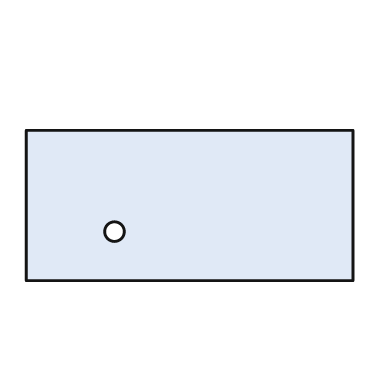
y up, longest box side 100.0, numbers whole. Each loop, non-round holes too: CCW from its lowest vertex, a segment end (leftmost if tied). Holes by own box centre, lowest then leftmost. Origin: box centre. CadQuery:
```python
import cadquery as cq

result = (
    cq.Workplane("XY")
    .moveTo(-50.0, -23.0)
    .lineTo(50.0, -23.0)
    .lineTo(50.0, 23.0)
    .lineTo(-50.0, 23.0)
    .close()
    .moveTo(-23.0, -8.0)
    .circle(3.0)
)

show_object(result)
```